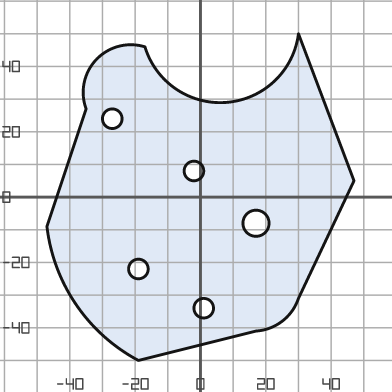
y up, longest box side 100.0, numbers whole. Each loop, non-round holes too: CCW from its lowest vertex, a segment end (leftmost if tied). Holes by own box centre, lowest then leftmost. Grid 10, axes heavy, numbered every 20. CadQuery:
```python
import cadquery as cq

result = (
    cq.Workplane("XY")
    .moveTo(-19.0, -50.0)
    .lineTo(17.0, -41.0)
    .threePointArc((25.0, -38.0), (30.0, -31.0))
    .lineTo(47.0, 5.0)
    .lineTo(30.0, 50.0)
    .threePointArc((8.0, 29.0), (-17.0, 46.0))
    .threePointArc((-32.0, 42.0), (-35.0, 27.0))
    .lineTo(-47.0, -9.0)
    .threePointArc((-38.0, -33.0), (-19.0, -50.0))
    .close()
    .moveTo(1.0, -34.0)
    .circle(3.0)
    .moveTo(-19.0, -22.0)
    .circle(3.0)
    .moveTo(17.0, -8.0)
    .circle(4.0)
    .moveTo(-2.0, 8.0)
    .circle(3.0)
    .moveTo(-27.0, 24.0)
    .circle(3.0)
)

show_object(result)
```